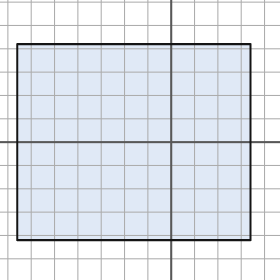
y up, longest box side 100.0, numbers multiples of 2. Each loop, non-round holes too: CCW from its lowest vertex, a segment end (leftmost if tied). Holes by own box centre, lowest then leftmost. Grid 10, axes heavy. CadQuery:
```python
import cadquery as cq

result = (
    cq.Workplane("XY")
    .moveTo(-66.0, -42.0)
    .lineTo(34.0, -42.0)
    .lineTo(34.0, 42.0)
    .lineTo(-66.0, 42.0)
    .close()
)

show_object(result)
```